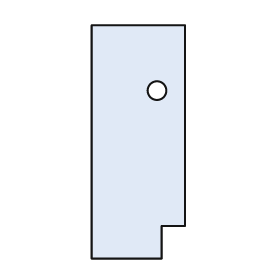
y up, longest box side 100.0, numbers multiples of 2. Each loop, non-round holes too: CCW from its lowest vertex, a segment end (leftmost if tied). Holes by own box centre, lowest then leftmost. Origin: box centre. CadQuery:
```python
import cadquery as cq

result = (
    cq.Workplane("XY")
    .moveTo(-20.0, -50.0)
    .lineTo(10.0, -50.0)
    .lineTo(10.0, -36.0)
    .lineTo(20.0, -36.0)
    .lineTo(20.0, 50.0)
    .lineTo(-20.0, 50.0)
    .close()
    .moveTo(8.0, 22.0)
    .circle(4.0)
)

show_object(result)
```